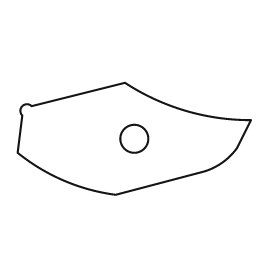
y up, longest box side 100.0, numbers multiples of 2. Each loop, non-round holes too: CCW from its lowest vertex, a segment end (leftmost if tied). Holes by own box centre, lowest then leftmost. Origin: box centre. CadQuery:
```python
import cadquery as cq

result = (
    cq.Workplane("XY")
    .moveTo(-8.0, -24.0)
    .lineTo(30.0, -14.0)
    .threePointArc((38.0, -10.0), (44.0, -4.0))
    .lineTo(50.0, 8.0)
    .threePointArc((22.0, 12.0), (-4.0, 24.0))
    .lineTo(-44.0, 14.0)
    .threePointArc((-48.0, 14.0), (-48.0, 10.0))
    .lineTo(-50.0, -6.0)
    .threePointArc((-30.0, -18.0), (-8.0, -24.0))
    .close()
    .moveTo(0.0, 0.0)
    .circle(6.0)
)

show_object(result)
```